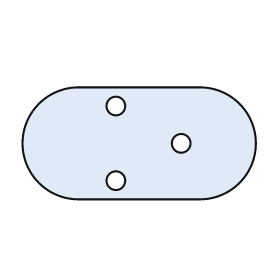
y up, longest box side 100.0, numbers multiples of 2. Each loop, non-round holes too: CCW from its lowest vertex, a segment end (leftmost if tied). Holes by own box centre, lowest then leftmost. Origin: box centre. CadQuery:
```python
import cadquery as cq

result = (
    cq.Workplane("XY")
    .moveTo(-26.0, -24.0)
    .lineTo(26.0, -24.0)
    .threePointArc((50.0, 0.0), (26.0, 24.0))
    .lineTo(-26.0, 24.0)
    .threePointArc((-50.0, 0.0), (-26.0, -24.0))
    .close()
    .moveTo(-10.0, -16.0)
    .circle(4.0)
    .moveTo(18.0, 0.0)
    .circle(4.0)
    .moveTo(-10.0, 16.0)
    .circle(4.0)
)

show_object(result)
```